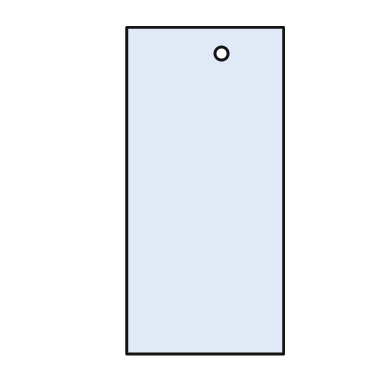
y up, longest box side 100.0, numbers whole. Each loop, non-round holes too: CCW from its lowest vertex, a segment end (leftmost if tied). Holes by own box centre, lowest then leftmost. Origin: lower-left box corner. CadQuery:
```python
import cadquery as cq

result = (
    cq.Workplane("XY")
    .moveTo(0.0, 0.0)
    .lineTo(48.0, 0.0)
    .lineTo(48.0, 100.0)
    .lineTo(0.0, 100.0)
    .close()
    .moveTo(29.0, 92.0)
    .circle(2.0)
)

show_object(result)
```